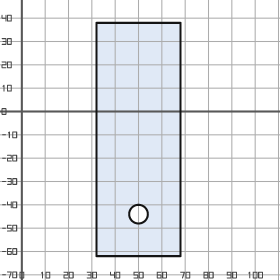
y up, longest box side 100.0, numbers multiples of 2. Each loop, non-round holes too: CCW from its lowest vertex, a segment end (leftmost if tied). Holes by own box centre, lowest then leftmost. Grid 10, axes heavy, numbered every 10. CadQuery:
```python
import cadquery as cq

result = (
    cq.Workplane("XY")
    .moveTo(32.0, -62.0)
    .lineTo(68.0, -62.0)
    .lineTo(68.0, 38.0)
    .lineTo(32.0, 38.0)
    .close()
    .moveTo(50.0, -44.0)
    .circle(4.0)
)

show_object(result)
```